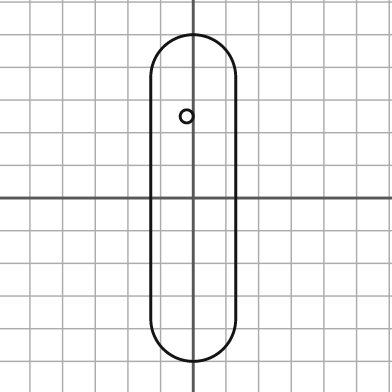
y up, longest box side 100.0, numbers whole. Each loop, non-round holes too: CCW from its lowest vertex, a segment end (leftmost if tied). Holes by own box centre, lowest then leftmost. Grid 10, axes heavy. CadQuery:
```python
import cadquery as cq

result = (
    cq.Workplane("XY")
    .moveTo(-13.0, -37.0)
    .threePointArc((0.0, -50.0), (13.0, -37.0))
    .lineTo(13.0, 37.0)
    .threePointArc((0.0, 50.0), (-13.0, 37.0))
    .close()
    .moveTo(-2.0, 25.0)
    .circle(2.0)
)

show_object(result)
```